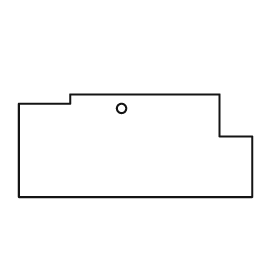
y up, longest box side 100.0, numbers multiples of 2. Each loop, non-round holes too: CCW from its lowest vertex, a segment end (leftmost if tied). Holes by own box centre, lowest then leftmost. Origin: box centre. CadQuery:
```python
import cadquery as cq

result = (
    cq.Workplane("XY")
    .moveTo(-50.0, -22.0)
    .lineTo(50.0, -22.0)
    .lineTo(50.0, 4.0)
    .lineTo(36.0, 4.0)
    .lineTo(36.0, 22.0)
    .lineTo(-28.0, 22.0)
    .lineTo(-28.0, 18.0)
    .lineTo(-50.0, 18.0)
    .close()
    .moveTo(-6.0, 16.0)
    .circle(2.0)
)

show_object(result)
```